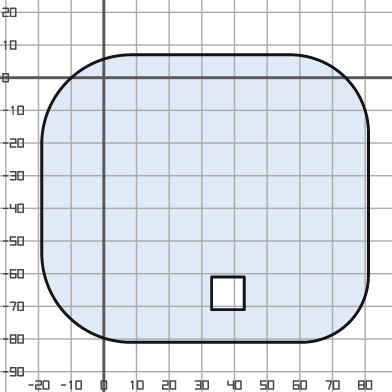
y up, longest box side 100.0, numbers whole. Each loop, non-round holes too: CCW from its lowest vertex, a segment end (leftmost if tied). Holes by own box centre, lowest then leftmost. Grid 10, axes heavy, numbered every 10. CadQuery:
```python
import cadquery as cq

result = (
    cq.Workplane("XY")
    .moveTo(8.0, -81.0)
    .lineTo(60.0, -81.0)
    .threePointArc((75.0, -75.0), (81.0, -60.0))
    .lineTo(81.0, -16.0)
    .threePointArc((74.0, 0.0), (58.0, 7.0))
    .lineTo(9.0, 7.0)
    .threePointArc((-11.0, -1.0), (-19.0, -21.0))
    .lineTo(-19.0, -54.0)
    .threePointArc((-11.0, -73.0), (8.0, -81.0))
    .close()
    .moveTo(33.0, -71.0)
    .lineTo(43.0, -71.0)
    .lineTo(43.0, -61.0)
    .lineTo(33.0, -61.0)
    .close()
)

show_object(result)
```